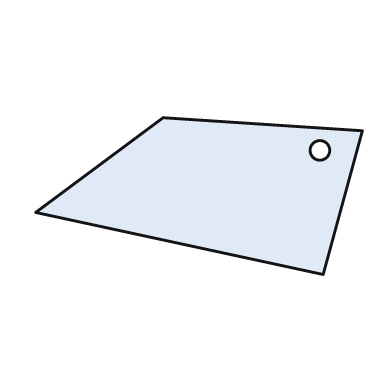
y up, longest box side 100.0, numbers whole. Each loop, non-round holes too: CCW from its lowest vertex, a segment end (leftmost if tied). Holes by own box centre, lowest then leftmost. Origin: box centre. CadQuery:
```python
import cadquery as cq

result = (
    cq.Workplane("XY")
    .moveTo(38.0, -24.0)
    .lineTo(50.0, 20.0)
    .lineTo(-11.0, 24.0)
    .lineTo(-50.0, -5.0)
    .close()
    .moveTo(37.0, 14.0)
    .circle(3.0)
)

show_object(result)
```